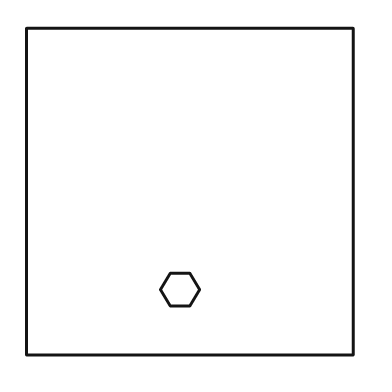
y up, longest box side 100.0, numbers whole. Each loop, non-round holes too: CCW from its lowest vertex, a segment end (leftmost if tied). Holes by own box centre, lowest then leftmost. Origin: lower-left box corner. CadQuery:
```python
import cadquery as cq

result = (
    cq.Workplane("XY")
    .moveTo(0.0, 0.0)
    .lineTo(100.0, 0.0)
    .lineTo(100.0, 100.0)
    .lineTo(0.0, 100.0)
    .close()
    .moveTo(44.0, 15.0)
    .lineTo(50.0, 15.0)
    .lineTo(53.0, 20.0)
    .lineTo(50.0, 25.0)
    .lineTo(44.0, 25.0)
    .lineTo(41.0, 20.0)
    .close()
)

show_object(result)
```